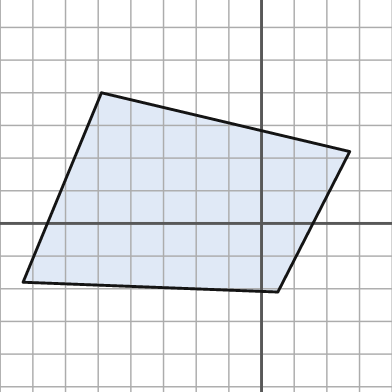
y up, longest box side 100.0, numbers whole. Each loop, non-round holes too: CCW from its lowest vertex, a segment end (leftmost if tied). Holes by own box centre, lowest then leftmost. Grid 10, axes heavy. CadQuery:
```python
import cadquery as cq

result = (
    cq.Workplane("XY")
    .moveTo(5.0, -21.0)
    .lineTo(27.0, 22.0)
    .lineTo(-49.0, 40.0)
    .lineTo(-73.0, -18.0)
    .close()
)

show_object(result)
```